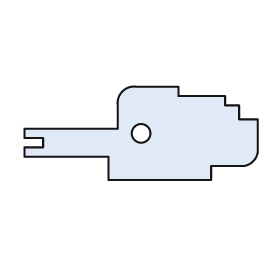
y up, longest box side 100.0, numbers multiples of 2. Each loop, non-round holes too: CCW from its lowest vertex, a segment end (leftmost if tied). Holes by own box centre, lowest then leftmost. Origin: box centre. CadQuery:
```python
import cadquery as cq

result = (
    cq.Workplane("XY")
    .moveTo(-14.0, -20.0)
    .lineTo(30.0, -20.0)
    .lineTo(30.0, -14.0)
    .lineTo(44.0, -14.0)
    .threePointArc((48.0, -12.0), (50.0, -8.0))
    .lineTo(50.0, 6.0)
    .lineTo(42.0, 6.0)
    .lineTo(42.0, 12.0)
    .lineTo(36.0, 12.0)
    .lineTo(36.0, 16.0)
    .lineTo(16.0, 16.0)
    .lineTo(16.0, 20.0)
    .lineTo(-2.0, 20.0)
    .threePointArc((-8.0, 18.0), (-10.0, 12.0))
    .lineTo(-10.0, 2.0)
    .lineTo(-50.0, 2.0)
    .lineTo(-50.0, -2.0)
    .lineTo(-42.0, -2.0)
    .lineTo(-42.0, -6.0)
    .lineTo(-50.0, -6.0)
    .lineTo(-50.0, -10.0)
    .lineTo(-14.0, -10.0)
    .close()
    .moveTo(0.0, 0.0)
    .circle(4.0)
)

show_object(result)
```